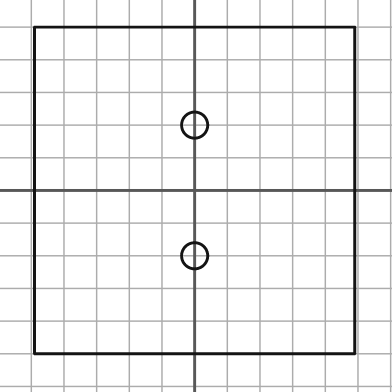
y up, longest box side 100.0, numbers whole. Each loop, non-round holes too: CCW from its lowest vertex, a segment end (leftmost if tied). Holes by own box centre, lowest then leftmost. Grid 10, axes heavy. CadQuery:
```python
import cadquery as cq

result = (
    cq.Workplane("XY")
    .moveTo(-49.0, -50.0)
    .lineTo(49.0, -50.0)
    .lineTo(49.0, 50.0)
    .lineTo(-49.0, 50.0)
    .close()
    .moveTo(0.0, -20.0)
    .circle(4.0)
    .moveTo(0.0, 20.0)
    .circle(4.0)
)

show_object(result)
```